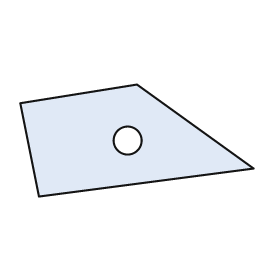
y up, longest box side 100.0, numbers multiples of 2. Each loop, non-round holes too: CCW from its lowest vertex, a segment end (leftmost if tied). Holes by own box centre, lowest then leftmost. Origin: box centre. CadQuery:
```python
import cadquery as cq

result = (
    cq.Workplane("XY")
    .moveTo(-42.0, -24.0)
    .lineTo(50.0, -12.0)
    .lineTo(0.0, 24.0)
    .lineTo(-50.0, 16.0)
    .close()
    .moveTo(-4.0, 0.0)
    .circle(6.0)
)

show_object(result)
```